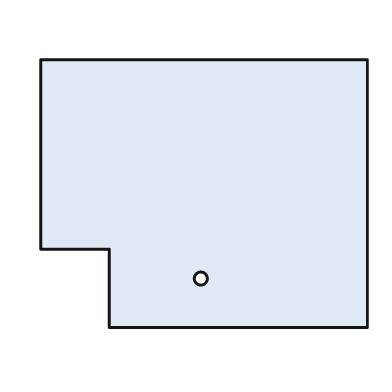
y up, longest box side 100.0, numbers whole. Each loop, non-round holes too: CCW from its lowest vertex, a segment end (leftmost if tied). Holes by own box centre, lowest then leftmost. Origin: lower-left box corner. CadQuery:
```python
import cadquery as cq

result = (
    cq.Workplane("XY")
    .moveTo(21.0, 0.0)
    .lineTo(100.0, 0.0)
    .lineTo(100.0, 82.0)
    .lineTo(0.0, 82.0)
    .lineTo(0.0, 24.0)
    .lineTo(21.0, 24.0)
    .close()
    .moveTo(49.0, 15.0)
    .circle(2.0)
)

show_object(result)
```